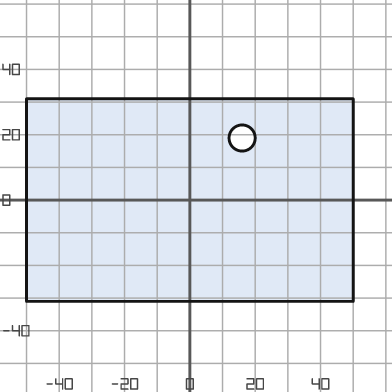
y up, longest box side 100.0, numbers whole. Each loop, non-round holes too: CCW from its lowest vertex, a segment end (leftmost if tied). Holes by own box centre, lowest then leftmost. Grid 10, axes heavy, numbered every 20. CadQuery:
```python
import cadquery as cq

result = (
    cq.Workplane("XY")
    .moveTo(-50.0, -31.0)
    .lineTo(50.0, -31.0)
    .lineTo(50.0, 31.0)
    .lineTo(-50.0, 31.0)
    .close()
    .moveTo(16.0, 19.0)
    .circle(4.0)
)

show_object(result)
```